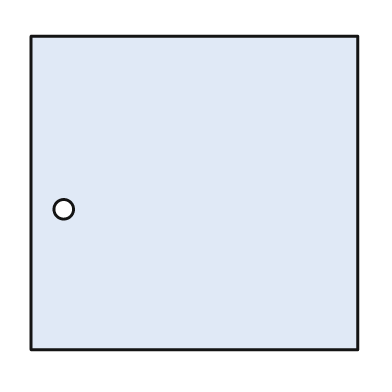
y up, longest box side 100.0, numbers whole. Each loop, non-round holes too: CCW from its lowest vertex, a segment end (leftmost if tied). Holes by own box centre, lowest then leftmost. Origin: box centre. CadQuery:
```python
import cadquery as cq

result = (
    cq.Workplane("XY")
    .moveTo(-50.0, -48.0)
    .lineTo(50.0, -48.0)
    .lineTo(50.0, 48.0)
    .lineTo(-50.0, 48.0)
    .close()
    .moveTo(-40.0, -5.0)
    .circle(3.0)
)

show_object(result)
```